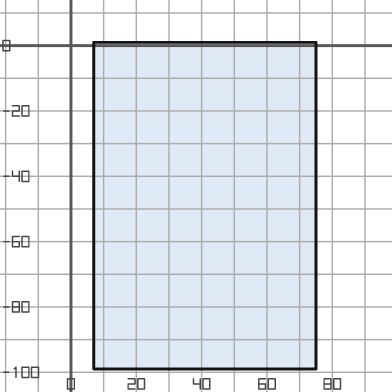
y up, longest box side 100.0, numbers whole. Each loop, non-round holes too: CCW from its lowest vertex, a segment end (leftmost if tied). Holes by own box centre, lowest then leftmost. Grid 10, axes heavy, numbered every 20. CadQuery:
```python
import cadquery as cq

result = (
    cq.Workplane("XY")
    .moveTo(7.0, -99.0)
    .lineTo(75.0, -99.0)
    .lineTo(75.0, 1.0)
    .lineTo(7.0, 1.0)
    .close()
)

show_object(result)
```